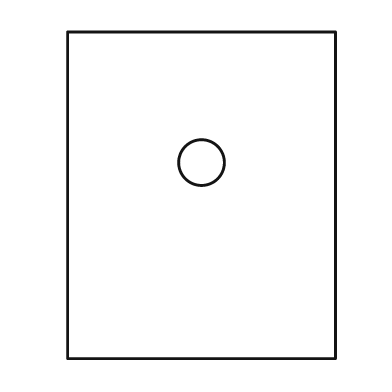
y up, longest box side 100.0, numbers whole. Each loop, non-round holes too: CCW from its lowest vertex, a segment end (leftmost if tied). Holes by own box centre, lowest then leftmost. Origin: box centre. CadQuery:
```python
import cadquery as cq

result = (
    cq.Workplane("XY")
    .moveTo(-41.0, -50.0)
    .lineTo(41.0, -50.0)
    .lineTo(41.0, 50.0)
    .lineTo(-41.0, 50.0)
    .close()
    .moveTo(0.0, 10.0)
    .circle(7.0)
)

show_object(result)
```